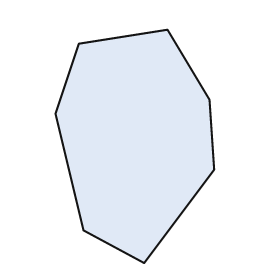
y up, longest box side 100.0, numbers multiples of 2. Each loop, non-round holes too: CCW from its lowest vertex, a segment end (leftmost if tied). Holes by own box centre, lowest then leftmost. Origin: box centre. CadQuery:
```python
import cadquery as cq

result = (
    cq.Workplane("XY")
    .moveTo(4.0, -50.0)
    .lineTo(34.0, -10.0)
    .lineTo(32.0, 20.0)
    .lineTo(14.0, 50.0)
    .lineTo(-24.0, 44.0)
    .lineTo(-34.0, 14.0)
    .lineTo(-22.0, -36.0)
    .close()
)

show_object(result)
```